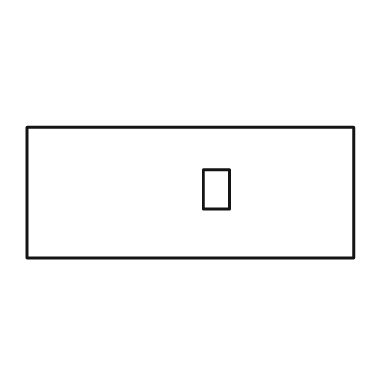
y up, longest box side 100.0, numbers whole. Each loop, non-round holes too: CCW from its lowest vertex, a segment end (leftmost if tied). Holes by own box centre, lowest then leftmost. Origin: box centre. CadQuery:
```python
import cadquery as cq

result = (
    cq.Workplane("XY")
    .moveTo(-50.0, -20.0)
    .lineTo(50.0, -20.0)
    .lineTo(50.0, 20.0)
    .lineTo(-50.0, 20.0)
    .close()
    .moveTo(4.0, -5.0)
    .lineTo(12.0, -5.0)
    .lineTo(12.0, 7.0)
    .lineTo(4.0, 7.0)
    .close()
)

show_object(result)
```